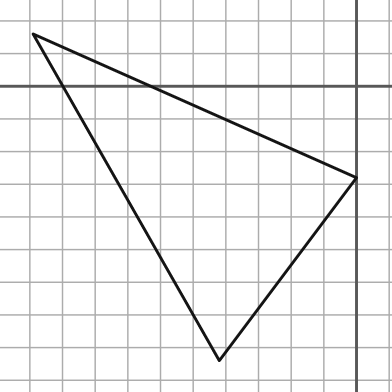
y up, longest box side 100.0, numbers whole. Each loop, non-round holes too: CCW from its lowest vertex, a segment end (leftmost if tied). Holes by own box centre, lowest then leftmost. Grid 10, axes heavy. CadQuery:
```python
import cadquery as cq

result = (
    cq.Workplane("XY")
    .moveTo(-42.0, -84.0)
    .lineTo(0.0, -28.0)
    .lineTo(-99.0, 16.0)
    .close()
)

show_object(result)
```